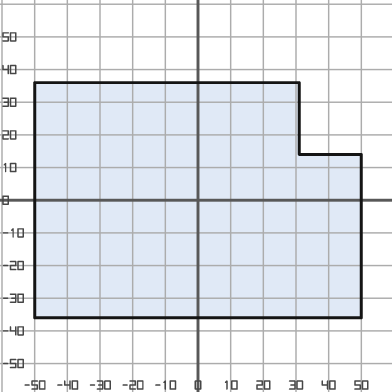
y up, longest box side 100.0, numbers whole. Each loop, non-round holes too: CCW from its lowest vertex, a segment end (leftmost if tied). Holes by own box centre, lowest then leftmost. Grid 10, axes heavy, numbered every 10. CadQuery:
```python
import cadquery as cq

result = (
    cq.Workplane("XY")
    .moveTo(-50.0, -36.0)
    .lineTo(50.0, -36.0)
    .lineTo(50.0, 14.0)
    .lineTo(31.0, 14.0)
    .lineTo(31.0, 36.0)
    .lineTo(-50.0, 36.0)
    .close()
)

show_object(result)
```